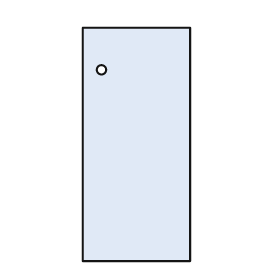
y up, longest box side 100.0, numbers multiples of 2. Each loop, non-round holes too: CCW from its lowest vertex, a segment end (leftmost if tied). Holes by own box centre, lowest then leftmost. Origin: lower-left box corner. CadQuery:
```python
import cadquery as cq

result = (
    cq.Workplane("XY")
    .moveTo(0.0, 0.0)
    .lineTo(46.0, 0.0)
    .lineTo(46.0, 100.0)
    .lineTo(0.0, 100.0)
    .close()
    .moveTo(8.0, 82.0)
    .circle(2.0)
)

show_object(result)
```